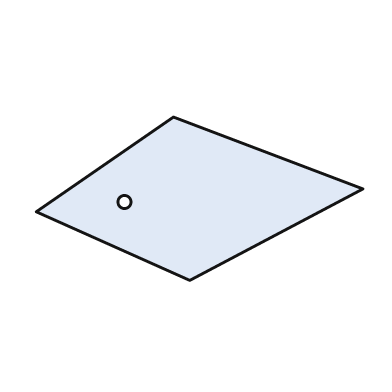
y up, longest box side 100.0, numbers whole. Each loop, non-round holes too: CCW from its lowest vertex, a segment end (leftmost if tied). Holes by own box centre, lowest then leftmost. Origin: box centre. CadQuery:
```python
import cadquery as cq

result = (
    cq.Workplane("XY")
    .moveTo(-3.0, -25.0)
    .lineTo(50.0, 3.0)
    .lineTo(-8.0, 25.0)
    .lineTo(-50.0, -4.0)
    .close()
    .moveTo(-23.0, -1.0)
    .circle(2.0)
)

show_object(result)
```